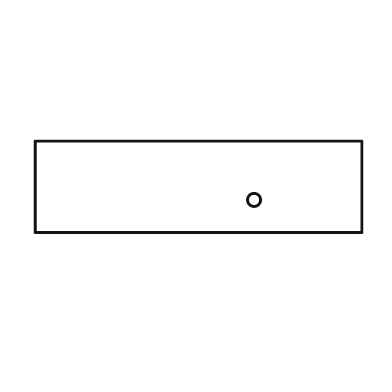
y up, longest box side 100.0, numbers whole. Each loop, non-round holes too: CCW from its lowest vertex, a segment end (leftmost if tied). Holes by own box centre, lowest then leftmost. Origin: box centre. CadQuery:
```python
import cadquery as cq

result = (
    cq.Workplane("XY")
    .moveTo(-50.0, -14.0)
    .lineTo(50.0, -14.0)
    .lineTo(50.0, 14.0)
    .lineTo(-50.0, 14.0)
    .close()
    .moveTo(17.0, -4.0)
    .circle(2.0)
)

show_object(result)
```